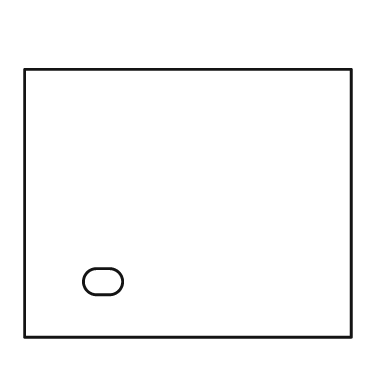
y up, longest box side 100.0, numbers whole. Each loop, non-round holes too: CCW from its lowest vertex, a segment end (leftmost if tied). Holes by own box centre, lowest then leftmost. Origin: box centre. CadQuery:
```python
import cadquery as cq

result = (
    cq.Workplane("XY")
    .moveTo(-50.0, -41.0)
    .lineTo(50.0, -41.0)
    .lineTo(50.0, 41.0)
    .lineTo(-50.0, 41.0)
    .close()
    .moveTo(-28.0, -28.0)
    .lineTo(-24.0, -28.0)
    .threePointArc((-20.0, -24.0), (-24.0, -20.0))
    .lineTo(-28.0, -20.0)
    .threePointArc((-32.0, -24.0), (-28.0, -28.0))
    .close()
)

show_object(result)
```